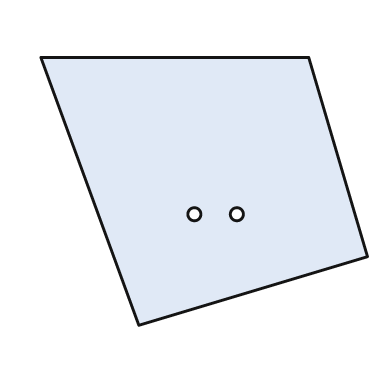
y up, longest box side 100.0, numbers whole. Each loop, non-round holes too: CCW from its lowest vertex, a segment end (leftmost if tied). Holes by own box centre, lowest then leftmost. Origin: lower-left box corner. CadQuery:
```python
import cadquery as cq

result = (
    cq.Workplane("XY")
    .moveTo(30.0, 0.0)
    .lineTo(100.0, 21.0)
    .lineTo(82.0, 82.0)
    .lineTo(0.0, 82.0)
    .close()
    .moveTo(47.0, 34.0)
    .circle(2.0)
    .moveTo(60.0, 34.0)
    .circle(2.0)
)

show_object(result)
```